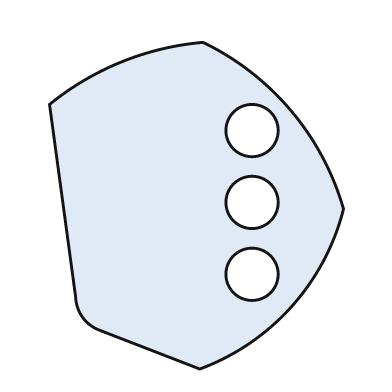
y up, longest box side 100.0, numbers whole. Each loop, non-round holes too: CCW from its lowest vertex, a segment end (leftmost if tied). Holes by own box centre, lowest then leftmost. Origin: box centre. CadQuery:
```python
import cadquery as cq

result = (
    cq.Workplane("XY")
    .moveTo(1.0, -50.0)
    .threePointArc((29.0, -31.0), (45.0, -1.0))
    .threePointArc((29.0, 29.0), (2.0, 50.0))
    .threePointArc((-23.0, 44.0), (-45.0, 31.0))
    .lineTo(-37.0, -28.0)
    .threePointArc((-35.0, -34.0), (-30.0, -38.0))
    .close()
    .moveTo(17.0, -21.0)
    .circle(8.0)
    .moveTo(17.0, 1.0)
    .circle(8.0)
    .moveTo(17.0, 23.0)
    .circle(8.0)
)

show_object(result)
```